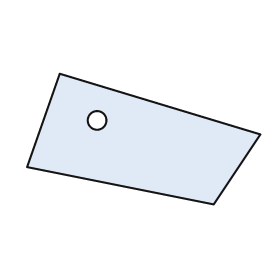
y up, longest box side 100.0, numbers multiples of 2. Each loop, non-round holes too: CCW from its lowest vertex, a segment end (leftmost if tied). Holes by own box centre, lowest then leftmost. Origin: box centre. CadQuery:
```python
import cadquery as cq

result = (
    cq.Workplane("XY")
    .moveTo(30.0, -28.0)
    .lineTo(50.0, 2.0)
    .lineTo(-36.0, 28.0)
    .lineTo(-50.0, -12.0)
    .close()
    .moveTo(-20.0, 8.0)
    .circle(4.0)
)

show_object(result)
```